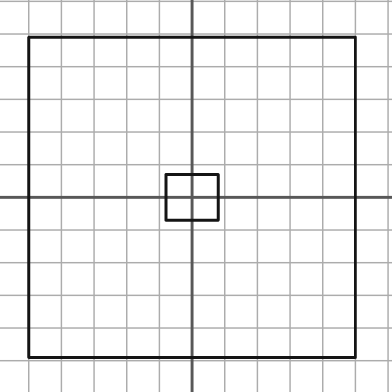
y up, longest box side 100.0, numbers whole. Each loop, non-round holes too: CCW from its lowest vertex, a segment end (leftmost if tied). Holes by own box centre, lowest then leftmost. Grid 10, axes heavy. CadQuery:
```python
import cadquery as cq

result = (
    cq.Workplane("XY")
    .moveTo(-50.0, -49.0)
    .lineTo(50.0, -49.0)
    .lineTo(50.0, 49.0)
    .lineTo(-50.0, 49.0)
    .close()
    .moveTo(-8.0, -7.0)
    .lineTo(8.0, -7.0)
    .lineTo(8.0, 7.0)
    .lineTo(-8.0, 7.0)
    .close()
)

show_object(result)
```